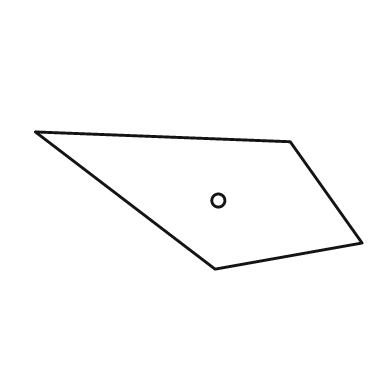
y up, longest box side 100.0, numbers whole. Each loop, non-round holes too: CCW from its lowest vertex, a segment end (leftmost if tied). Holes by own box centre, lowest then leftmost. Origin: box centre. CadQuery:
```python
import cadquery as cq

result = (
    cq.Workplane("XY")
    .moveTo(5.0, -21.0)
    .lineTo(50.0, -13.0)
    .lineTo(28.0, 18.0)
    .lineTo(-50.0, 21.0)
    .close()
    .moveTo(6.0, 0.0)
    .circle(2.0)
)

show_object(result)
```